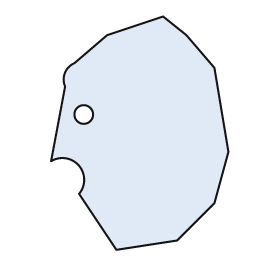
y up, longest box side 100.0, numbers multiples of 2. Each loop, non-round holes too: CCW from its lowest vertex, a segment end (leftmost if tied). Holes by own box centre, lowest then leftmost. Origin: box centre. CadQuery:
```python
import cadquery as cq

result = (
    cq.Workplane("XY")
    .moveTo(-10.0, -50.0)
    .lineTo(16.0, -46.0)
    .lineTo(32.0, -30.0)
    .lineTo(38.0, -8.0)
    .lineTo(32.0, 28.0)
    .lineTo(20.0, 42.0)
    .lineTo(10.0, 50.0)
    .lineTo(-14.0, 42.0)
    .lineTo(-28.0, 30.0)
    .threePointArc((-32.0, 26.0), (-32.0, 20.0))
    .lineTo(-38.0, -12.0)
    .threePointArc((-26.0, -14.0), (-26.0, -26.0))
    .close()
    .moveTo(-24.0, 8.0)
    .circle(4.0)
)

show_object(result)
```